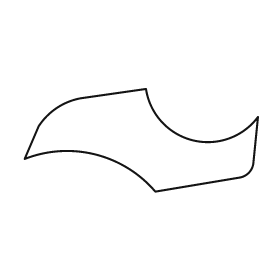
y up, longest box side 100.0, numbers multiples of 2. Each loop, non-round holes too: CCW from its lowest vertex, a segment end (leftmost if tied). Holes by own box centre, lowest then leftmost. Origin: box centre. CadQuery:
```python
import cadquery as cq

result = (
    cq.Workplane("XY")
    .moveTo(6.0, -22.0)
    .lineTo(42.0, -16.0)
    .threePointArc((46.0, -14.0), (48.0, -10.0))
    .lineTo(50.0, 10.0)
    .threePointArc((22.0, 0.0), (2.0, 22.0))
    .lineTo(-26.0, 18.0)
    .threePointArc((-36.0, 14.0), (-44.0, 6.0))
    .lineTo(-50.0, -8.0)
    .threePointArc((-20.0, -6.0), (6.0, -22.0))
    .close()
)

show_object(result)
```